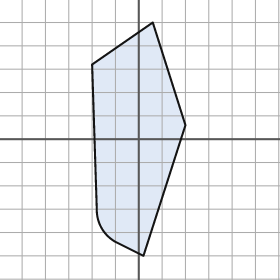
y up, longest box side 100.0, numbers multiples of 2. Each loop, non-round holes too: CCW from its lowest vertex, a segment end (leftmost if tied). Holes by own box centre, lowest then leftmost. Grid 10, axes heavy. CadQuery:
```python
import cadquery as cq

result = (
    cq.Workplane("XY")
    .moveTo(2.0, -50.0)
    .lineTo(20.0, 6.0)
    .lineTo(6.0, 50.0)
    .lineTo(-20.0, 32.0)
    .lineTo(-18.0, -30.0)
    .threePointArc((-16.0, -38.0), (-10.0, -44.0))
    .close()
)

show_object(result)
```